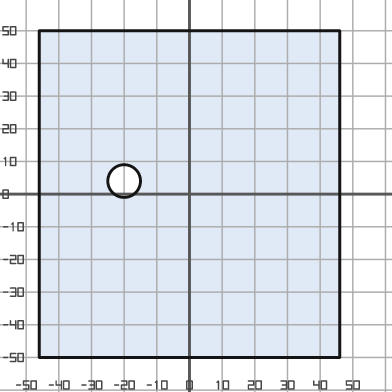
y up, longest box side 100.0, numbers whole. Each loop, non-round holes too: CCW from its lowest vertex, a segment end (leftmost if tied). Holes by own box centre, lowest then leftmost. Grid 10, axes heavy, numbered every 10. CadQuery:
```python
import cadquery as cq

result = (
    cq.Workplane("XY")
    .moveTo(-46.0, -50.0)
    .lineTo(46.0, -50.0)
    .lineTo(46.0, 50.0)
    .lineTo(-46.0, 50.0)
    .close()
    .moveTo(-20.0, 4.0)
    .circle(5.0)
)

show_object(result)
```